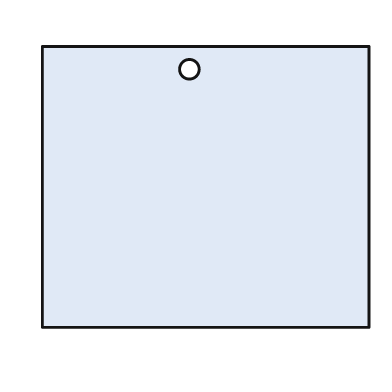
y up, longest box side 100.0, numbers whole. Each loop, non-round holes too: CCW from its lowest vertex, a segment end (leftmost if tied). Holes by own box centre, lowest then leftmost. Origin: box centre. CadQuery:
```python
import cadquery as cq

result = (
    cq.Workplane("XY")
    .moveTo(-50.0, -43.0)
    .lineTo(50.0, -43.0)
    .lineTo(50.0, 43.0)
    .lineTo(-50.0, 43.0)
    .close()
    .moveTo(-5.0, 36.0)
    .circle(3.0)
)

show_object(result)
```